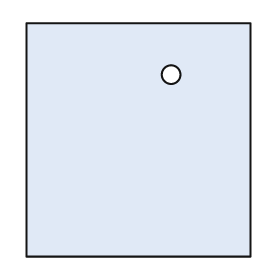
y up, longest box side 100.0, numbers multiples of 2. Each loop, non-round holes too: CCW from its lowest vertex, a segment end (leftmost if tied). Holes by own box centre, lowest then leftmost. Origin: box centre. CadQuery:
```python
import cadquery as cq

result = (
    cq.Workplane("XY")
    .moveTo(-48.0, -50.0)
    .lineTo(48.0, -50.0)
    .lineTo(48.0, 50.0)
    .lineTo(-48.0, 50.0)
    .close()
    .moveTo(14.0, 28.0)
    .circle(4.0)
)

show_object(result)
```